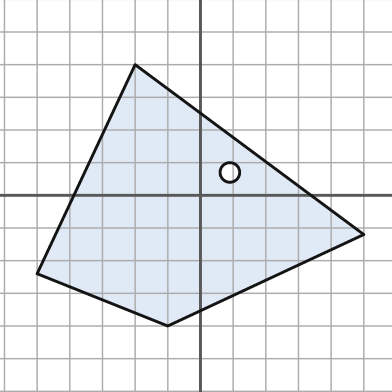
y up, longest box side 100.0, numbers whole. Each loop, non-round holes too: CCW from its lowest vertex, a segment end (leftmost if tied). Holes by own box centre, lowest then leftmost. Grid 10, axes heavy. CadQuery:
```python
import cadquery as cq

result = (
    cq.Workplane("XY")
    .moveTo(-10.0, -40.0)
    .lineTo(50.0, -12.0)
    .lineTo(-20.0, 40.0)
    .lineTo(-50.0, -24.0)
    .close()
    .moveTo(9.0, 7.0)
    .circle(3.0)
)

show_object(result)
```